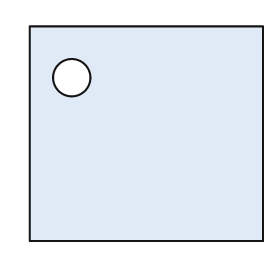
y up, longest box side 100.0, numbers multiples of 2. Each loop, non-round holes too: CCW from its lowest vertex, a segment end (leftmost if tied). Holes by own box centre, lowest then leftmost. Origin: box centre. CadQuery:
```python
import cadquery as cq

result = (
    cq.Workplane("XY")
    .moveTo(-50.0, -46.0)
    .lineTo(50.0, -46.0)
    .lineTo(50.0, 46.0)
    .lineTo(-50.0, 46.0)
    .close()
    .moveTo(-32.0, 24.0)
    .circle(8.0)
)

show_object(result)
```